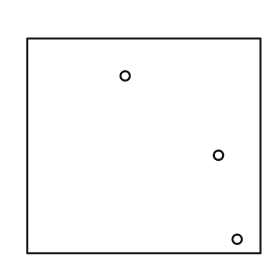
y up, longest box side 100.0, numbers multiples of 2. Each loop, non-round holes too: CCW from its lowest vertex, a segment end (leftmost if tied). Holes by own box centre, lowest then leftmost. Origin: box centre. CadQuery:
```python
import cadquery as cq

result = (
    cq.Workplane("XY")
    .moveTo(-50.0, -46.0)
    .lineTo(50.0, -46.0)
    .lineTo(50.0, 46.0)
    .lineTo(-50.0, 46.0)
    .close()
    .moveTo(40.0, -40.0)
    .circle(2.0)
    .moveTo(32.0, -4.0)
    .circle(2.0)
    .moveTo(-8.0, 30.0)
    .circle(2.0)
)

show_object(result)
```